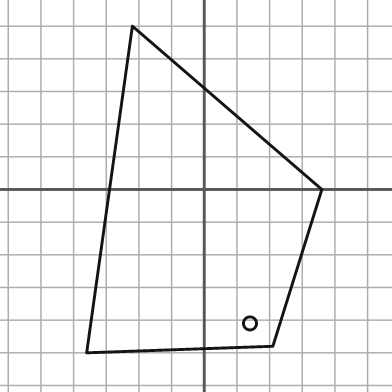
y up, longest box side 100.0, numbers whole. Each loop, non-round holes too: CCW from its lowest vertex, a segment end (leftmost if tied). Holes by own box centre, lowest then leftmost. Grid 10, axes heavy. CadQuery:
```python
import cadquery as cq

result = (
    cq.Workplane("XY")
    .moveTo(-36.0, -50.0)
    .lineTo(21.0, -48.0)
    .lineTo(36.0, 0.0)
    .lineTo(-22.0, 50.0)
    .close()
    .moveTo(14.0, -41.0)
    .circle(2.0)
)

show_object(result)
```